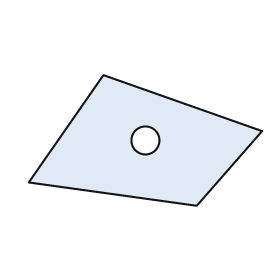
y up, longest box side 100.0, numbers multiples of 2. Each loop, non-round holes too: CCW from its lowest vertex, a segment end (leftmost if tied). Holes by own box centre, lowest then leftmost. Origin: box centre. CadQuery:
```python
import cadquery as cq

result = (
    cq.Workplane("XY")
    .moveTo(22.0, -28.0)
    .lineTo(50.0, 4.0)
    .lineTo(-18.0, 28.0)
    .lineTo(-50.0, -18.0)
    .close()
    .moveTo(0.0, 0.0)
    .circle(6.0)
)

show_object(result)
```